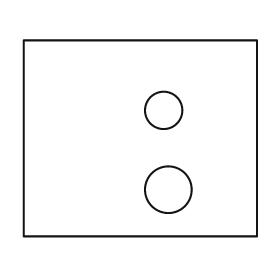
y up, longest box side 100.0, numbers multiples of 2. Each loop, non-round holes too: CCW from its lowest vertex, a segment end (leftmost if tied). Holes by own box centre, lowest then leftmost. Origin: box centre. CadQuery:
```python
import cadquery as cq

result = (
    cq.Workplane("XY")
    .moveTo(-50.0, -42.0)
    .lineTo(50.0, -42.0)
    .lineTo(50.0, 42.0)
    .lineTo(-50.0, 42.0)
    .close()
    .moveTo(12.0, -22.0)
    .circle(10.0)
    .moveTo(10.0, 12.0)
    .circle(8.0)
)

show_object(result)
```